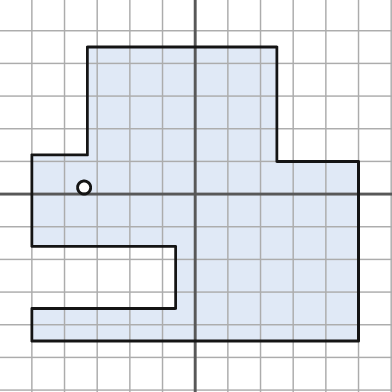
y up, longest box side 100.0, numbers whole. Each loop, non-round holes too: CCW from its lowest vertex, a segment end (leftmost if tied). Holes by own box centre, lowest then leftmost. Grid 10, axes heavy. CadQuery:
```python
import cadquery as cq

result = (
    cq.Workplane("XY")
    .moveTo(-50.0, -45.0)
    .lineTo(50.0, -45.0)
    .lineTo(50.0, 10.0)
    .lineTo(25.0, 10.0)
    .lineTo(25.0, 45.0)
    .lineTo(-33.0, 45.0)
    .lineTo(-33.0, 12.0)
    .lineTo(-50.0, 12.0)
    .lineTo(-50.0, -16.0)
    .lineTo(-6.0, -16.0)
    .lineTo(-6.0, -35.0)
    .lineTo(-50.0, -35.0)
    .close()
    .moveTo(-34.0, 2.0)
    .circle(2.0)
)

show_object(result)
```